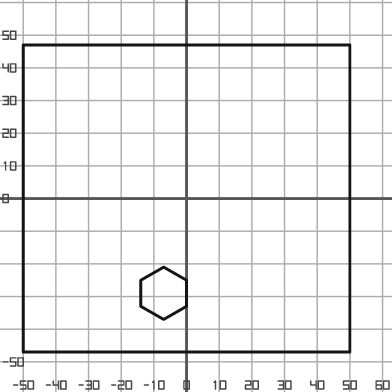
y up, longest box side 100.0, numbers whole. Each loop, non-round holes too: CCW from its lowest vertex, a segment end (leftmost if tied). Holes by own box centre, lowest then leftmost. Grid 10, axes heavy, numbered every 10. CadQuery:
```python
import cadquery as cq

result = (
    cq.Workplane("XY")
    .moveTo(-50.0, -47.0)
    .lineTo(50.0, -47.0)
    .lineTo(50.0, 47.0)
    .lineTo(-50.0, 47.0)
    .close()
    .moveTo(-7.0, -37.0)
    .lineTo(0.0, -33.0)
    .lineTo(0.0, -25.0)
    .lineTo(-7.0, -21.0)
    .lineTo(-14.0, -25.0)
    .lineTo(-14.0, -33.0)
    .close()
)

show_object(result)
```